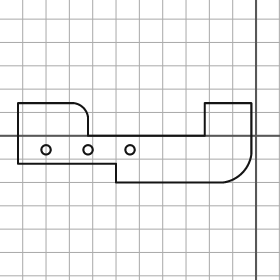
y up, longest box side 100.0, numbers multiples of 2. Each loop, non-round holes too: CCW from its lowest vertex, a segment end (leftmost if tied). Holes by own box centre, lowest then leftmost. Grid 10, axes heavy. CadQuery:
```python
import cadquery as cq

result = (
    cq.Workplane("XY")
    .moveTo(-60.0, -20.0)
    .lineTo(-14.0, -20.0)
    .threePointArc((-6.0, -16.0), (-2.0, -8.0))
    .lineTo(-2.0, 14.0)
    .lineTo(-22.0, 14.0)
    .lineTo(-22.0, 0.0)
    .lineTo(-72.0, 0.0)
    .lineTo(-72.0, 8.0)
    .threePointArc((-74.0, 12.0), (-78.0, 14.0))
    .lineTo(-102.0, 14.0)
    .lineTo(-102.0, -12.0)
    .lineTo(-60.0, -12.0)
    .close()
    .moveTo(-90.0, -6.0)
    .circle(2.0)
    .moveTo(-72.0, -6.0)
    .circle(2.0)
    .moveTo(-54.0, -6.0)
    .circle(2.0)
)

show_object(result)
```